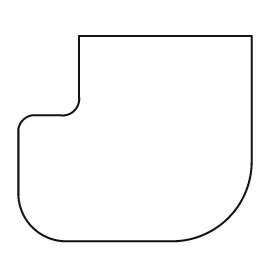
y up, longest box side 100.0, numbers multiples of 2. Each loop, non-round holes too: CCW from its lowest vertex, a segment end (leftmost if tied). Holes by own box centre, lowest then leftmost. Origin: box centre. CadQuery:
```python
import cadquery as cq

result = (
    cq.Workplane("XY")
    .moveTo(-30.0, -44.0)
    .lineTo(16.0, -44.0)
    .threePointArc((40.0, -34.0), (50.0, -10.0))
    .lineTo(50.0, 44.0)
    .lineTo(-24.0, 44.0)
    .lineTo(-24.0, 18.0)
    .threePointArc((-26.0, 12.0), (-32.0, 10.0))
    .lineTo(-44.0, 10.0)
    .threePointArc((-48.0, 8.0), (-50.0, 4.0))
    .lineTo(-50.0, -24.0)
    .threePointArc((-44.0, -38.0), (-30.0, -44.0))
    .close()
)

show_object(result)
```